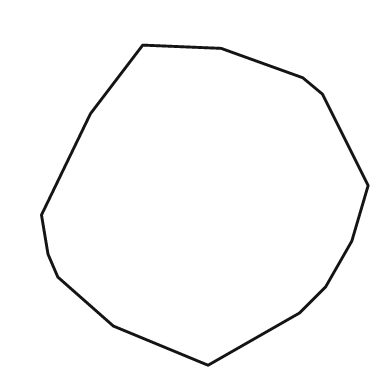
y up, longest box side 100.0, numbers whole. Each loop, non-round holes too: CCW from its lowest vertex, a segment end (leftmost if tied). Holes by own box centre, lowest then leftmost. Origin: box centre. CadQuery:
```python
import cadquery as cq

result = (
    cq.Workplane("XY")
    .moveTo(1.0, -49.0)
    .lineTo(29.0, -33.0)
    .lineTo(37.0, -25.0)
    .lineTo(45.0, -11.0)
    .lineTo(50.0, 6.0)
    .lineTo(36.0, 34.0)
    .lineTo(30.0, 39.0)
    .lineTo(5.0, 48.0)
    .lineTo(-19.0, 49.0)
    .lineTo(-35.0, 28.0)
    .lineTo(-50.0, -3.0)
    .lineTo(-48.0, -15.0)
    .lineTo(-45.0, -22.0)
    .lineTo(-28.0, -37.0)
    .close()
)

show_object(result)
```